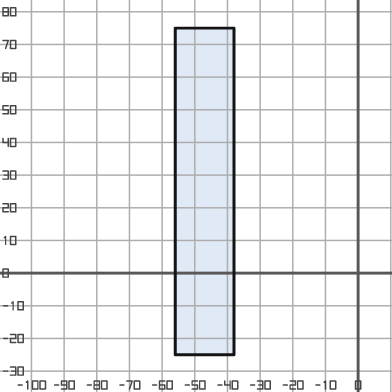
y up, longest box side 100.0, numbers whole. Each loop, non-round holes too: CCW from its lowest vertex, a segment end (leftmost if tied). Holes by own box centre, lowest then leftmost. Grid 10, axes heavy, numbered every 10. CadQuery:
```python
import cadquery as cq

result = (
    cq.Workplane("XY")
    .moveTo(-56.0, -25.0)
    .lineTo(-38.0, -25.0)
    .lineTo(-38.0, 75.0)
    .lineTo(-56.0, 75.0)
    .close()
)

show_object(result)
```